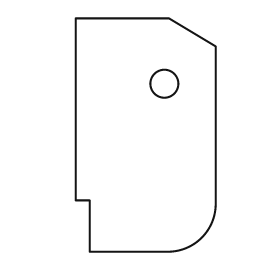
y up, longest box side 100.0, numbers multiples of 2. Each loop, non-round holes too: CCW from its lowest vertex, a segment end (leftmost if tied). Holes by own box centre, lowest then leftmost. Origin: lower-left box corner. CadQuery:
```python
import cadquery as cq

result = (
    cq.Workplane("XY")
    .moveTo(6.0, 0.0)
    .lineTo(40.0, 0.0)
    .threePointArc((54.0, 6.0), (60.0, 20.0))
    .lineTo(60.0, 88.0)
    .lineTo(40.0, 100.0)
    .lineTo(0.0, 100.0)
    .lineTo(0.0, 22.0)
    .lineTo(6.0, 22.0)
    .close()
    .moveTo(38.0, 72.0)
    .circle(6.0)
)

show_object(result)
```